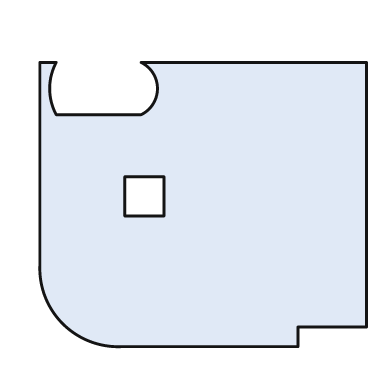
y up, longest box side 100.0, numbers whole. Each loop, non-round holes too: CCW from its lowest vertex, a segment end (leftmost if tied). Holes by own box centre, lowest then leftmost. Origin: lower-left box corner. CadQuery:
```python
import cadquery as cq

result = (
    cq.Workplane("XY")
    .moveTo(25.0, 0.0)
    .lineTo(79.0, 0.0)
    .lineTo(79.0, 6.0)
    .lineTo(100.0, 6.0)
    .lineTo(100.0, 87.0)
    .lineTo(31.0, 87.0)
    .threePointArc((36.0, 79.0), (31.0, 71.0))
    .lineTo(5.0, 71.0)
    .threePointArc((3.0, 79.0), (5.0, 87.0))
    .lineTo(0.0, 87.0)
    .lineTo(0.0, 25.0)
    .threePointArc((7.0, 7.0), (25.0, 0.0))
    .close()
    .moveTo(26.0, 40.0)
    .lineTo(38.0, 40.0)
    .lineTo(38.0, 52.0)
    .lineTo(26.0, 52.0)
    .close()
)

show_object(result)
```